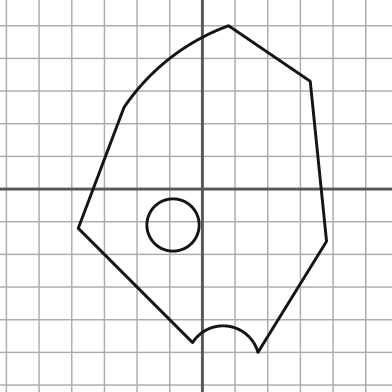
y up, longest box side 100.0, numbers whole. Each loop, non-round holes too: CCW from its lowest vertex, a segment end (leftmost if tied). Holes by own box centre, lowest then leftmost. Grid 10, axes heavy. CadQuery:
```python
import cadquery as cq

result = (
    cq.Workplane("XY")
    .moveTo(17.0, -50.0)
    .lineTo(38.0, -16.0)
    .lineTo(33.0, 33.0)
    .lineTo(8.0, 50.0)
    .threePointArc((-10.0, 40.0), (-24.0, 25.0))
    .lineTo(-38.0, -12.0)
    .lineTo(-3.0, -47.0)
    .threePointArc((8.0, -42.0), (17.0, -50.0))
    .close()
    .moveTo(-9.0, -11.0)
    .circle(8.0)
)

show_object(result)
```